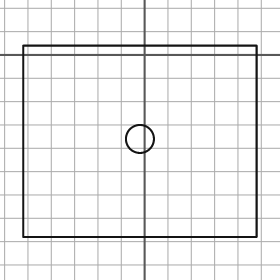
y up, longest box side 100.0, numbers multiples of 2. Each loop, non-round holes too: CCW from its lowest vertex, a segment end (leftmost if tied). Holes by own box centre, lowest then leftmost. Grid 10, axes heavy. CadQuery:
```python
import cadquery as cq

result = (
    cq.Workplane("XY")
    .moveTo(-52.0, -78.0)
    .lineTo(48.0, -78.0)
    .lineTo(48.0, 4.0)
    .lineTo(-52.0, 4.0)
    .close()
    .moveTo(-2.0, -36.0)
    .circle(6.0)
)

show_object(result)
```